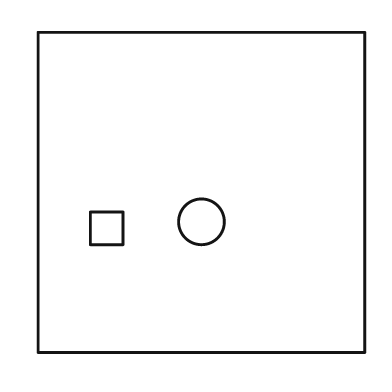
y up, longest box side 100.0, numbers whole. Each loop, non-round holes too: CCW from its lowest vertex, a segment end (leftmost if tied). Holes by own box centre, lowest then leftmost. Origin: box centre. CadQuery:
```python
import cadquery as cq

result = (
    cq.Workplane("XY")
    .moveTo(-50.0, -49.0)
    .lineTo(50.0, -49.0)
    .lineTo(50.0, 49.0)
    .lineTo(-50.0, 49.0)
    .close()
    .moveTo(-34.0, -16.0)
    .lineTo(-24.0, -16.0)
    .lineTo(-24.0, -6.0)
    .lineTo(-34.0, -6.0)
    .close()
    .moveTo(0.0, -9.0)
    .circle(7.0)
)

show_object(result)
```